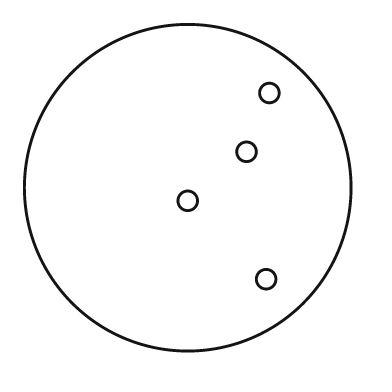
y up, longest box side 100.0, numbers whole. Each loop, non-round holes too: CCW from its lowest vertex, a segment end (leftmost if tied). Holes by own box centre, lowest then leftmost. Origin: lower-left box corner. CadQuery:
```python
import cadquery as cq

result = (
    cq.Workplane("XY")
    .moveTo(50.0, 50.0)
    .circle(50.0)
    .moveTo(74.0, 22.0)
    .circle(3.0)
    .moveTo(50.0, 46.0)
    .circle(3.0)
    .moveTo(68.0, 61.0)
    .circle(3.0)
    .moveTo(75.0, 79.0)
    .circle(3.0)
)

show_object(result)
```